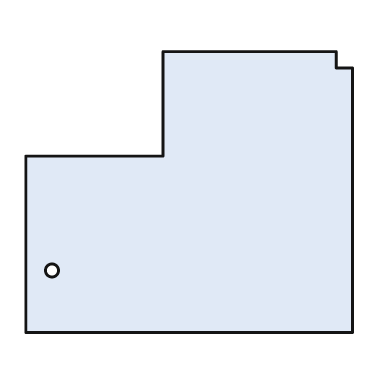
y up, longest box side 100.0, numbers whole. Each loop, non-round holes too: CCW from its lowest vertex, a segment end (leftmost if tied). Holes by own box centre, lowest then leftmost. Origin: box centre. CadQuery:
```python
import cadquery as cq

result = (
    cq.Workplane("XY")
    .moveTo(-50.0, -43.0)
    .lineTo(50.0, -43.0)
    .lineTo(50.0, 38.0)
    .lineTo(45.0, 38.0)
    .lineTo(45.0, 43.0)
    .lineTo(-8.0, 43.0)
    .lineTo(-8.0, 11.0)
    .lineTo(-50.0, 11.0)
    .close()
    .moveTo(-42.0, -24.0)
    .circle(2.0)
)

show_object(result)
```